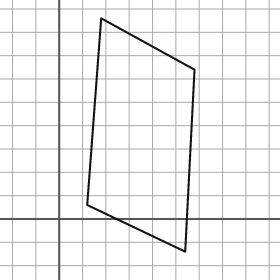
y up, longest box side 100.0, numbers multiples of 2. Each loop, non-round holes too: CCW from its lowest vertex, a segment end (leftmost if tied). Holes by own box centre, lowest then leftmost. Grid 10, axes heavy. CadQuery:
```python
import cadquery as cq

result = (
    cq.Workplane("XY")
    .moveTo(54.0, -14.0)
    .lineTo(58.0, 64.0)
    .lineTo(18.0, 86.0)
    .lineTo(12.0, 6.0)
    .close()
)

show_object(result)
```